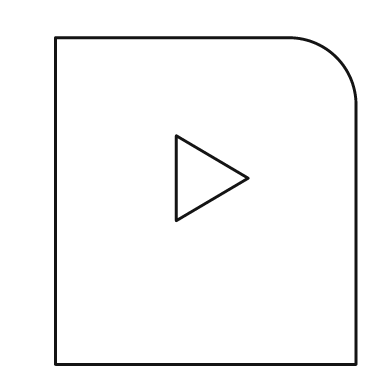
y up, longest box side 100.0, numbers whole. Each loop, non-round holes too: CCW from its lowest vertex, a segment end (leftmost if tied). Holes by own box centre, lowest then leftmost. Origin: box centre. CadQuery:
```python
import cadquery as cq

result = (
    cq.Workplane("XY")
    .moveTo(-46.0, -50.0)
    .lineTo(46.0, -50.0)
    .lineTo(46.0, 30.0)
    .threePointArc((40.0, 44.0), (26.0, 50.0))
    .lineTo(-46.0, 50.0)
    .close()
    .moveTo(-9.0, -6.0)
    .lineTo(13.0, 7.0)
    .lineTo(-9.0, 20.0)
    .close()
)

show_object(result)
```